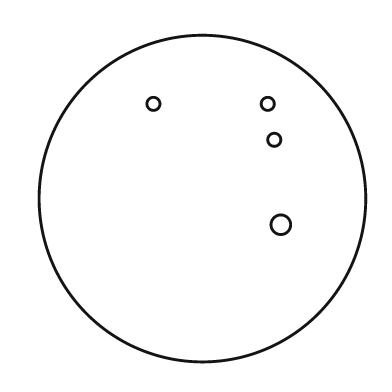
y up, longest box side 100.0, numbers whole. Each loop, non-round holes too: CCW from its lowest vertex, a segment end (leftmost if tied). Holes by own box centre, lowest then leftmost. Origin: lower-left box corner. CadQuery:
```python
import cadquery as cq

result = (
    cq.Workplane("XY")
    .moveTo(50.0, 50.0)
    .circle(50.0)
    .moveTo(74.0, 42.0)
    .circle(3.0)
    .moveTo(72.0, 68.0)
    .circle(2.0)
    .moveTo(35.0, 79.0)
    .circle(2.0)
    .moveTo(70.0, 79.0)
    .circle(2.0)
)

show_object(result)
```